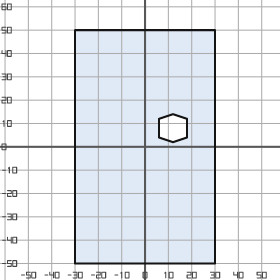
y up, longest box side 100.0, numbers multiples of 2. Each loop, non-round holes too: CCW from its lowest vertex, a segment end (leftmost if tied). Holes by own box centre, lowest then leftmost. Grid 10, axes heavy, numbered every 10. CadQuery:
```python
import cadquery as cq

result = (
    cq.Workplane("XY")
    .moveTo(-30.0, -50.0)
    .lineTo(30.0, -50.0)
    .lineTo(30.0, 50.0)
    .lineTo(-30.0, 50.0)
    .close()
    .moveTo(12.0, 2.0)
    .lineTo(18.0, 4.0)
    .lineTo(18.0, 12.0)
    .lineTo(12.0, 14.0)
    .lineTo(6.0, 12.0)
    .lineTo(6.0, 4.0)
    .close()
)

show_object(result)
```